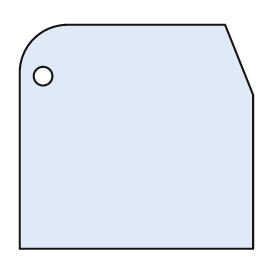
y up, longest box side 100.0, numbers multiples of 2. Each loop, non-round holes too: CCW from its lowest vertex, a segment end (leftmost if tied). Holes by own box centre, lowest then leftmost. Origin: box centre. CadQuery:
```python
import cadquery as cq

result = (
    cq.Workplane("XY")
    .moveTo(-50.0, -48.0)
    .lineTo(50.0, -48.0)
    .lineTo(50.0, 18.0)
    .lineTo(38.0, 48.0)
    .lineTo(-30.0, 48.0)
    .threePointArc((-44.0, 42.0), (-50.0, 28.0))
    .close()
    .moveTo(-40.0, 26.0)
    .circle(4.0)
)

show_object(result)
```